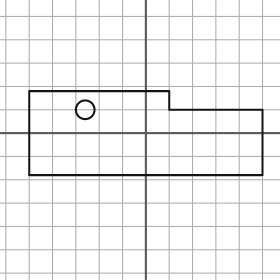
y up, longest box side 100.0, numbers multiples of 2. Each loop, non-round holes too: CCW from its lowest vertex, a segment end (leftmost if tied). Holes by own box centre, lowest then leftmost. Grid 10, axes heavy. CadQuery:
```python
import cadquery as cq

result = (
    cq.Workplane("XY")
    .moveTo(-50.0, -18.0)
    .lineTo(50.0, -18.0)
    .lineTo(50.0, 10.0)
    .lineTo(10.0, 10.0)
    .lineTo(10.0, 18.0)
    .lineTo(-50.0, 18.0)
    .close()
    .moveTo(-26.0, 10.0)
    .circle(4.0)
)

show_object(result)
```